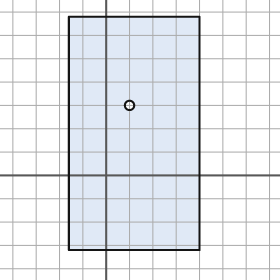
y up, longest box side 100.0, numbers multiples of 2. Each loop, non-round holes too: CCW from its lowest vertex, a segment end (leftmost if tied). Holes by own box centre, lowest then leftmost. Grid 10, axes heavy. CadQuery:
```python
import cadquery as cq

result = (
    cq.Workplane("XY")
    .moveTo(-16.0, -32.0)
    .lineTo(40.0, -32.0)
    .lineTo(40.0, 68.0)
    .lineTo(-16.0, 68.0)
    .close()
    .moveTo(10.0, 30.0)
    .circle(2.0)
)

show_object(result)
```